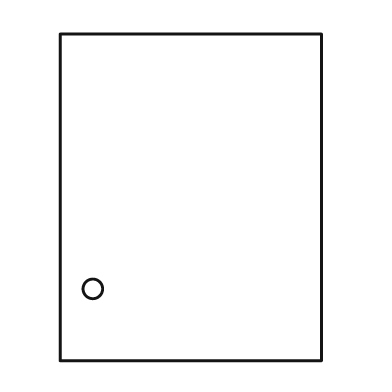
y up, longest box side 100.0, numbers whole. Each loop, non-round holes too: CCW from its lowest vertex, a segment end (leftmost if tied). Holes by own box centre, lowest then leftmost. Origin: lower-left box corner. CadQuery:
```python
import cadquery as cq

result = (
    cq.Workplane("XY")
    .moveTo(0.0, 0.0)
    .lineTo(80.0, 0.0)
    .lineTo(80.0, 100.0)
    .lineTo(0.0, 100.0)
    .close()
    .moveTo(10.0, 22.0)
    .circle(3.0)
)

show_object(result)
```